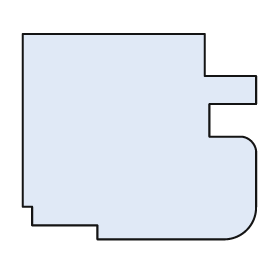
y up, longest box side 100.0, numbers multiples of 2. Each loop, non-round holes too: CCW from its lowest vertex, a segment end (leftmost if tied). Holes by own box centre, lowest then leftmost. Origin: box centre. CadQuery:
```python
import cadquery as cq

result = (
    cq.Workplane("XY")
    .moveTo(-18.0, -44.0)
    .lineTo(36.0, -44.0)
    .threePointArc((46.0, -40.0), (50.0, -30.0))
    .lineTo(50.0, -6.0)
    .threePointArc((48.0, -2.0), (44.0, 0.0))
    .lineTo(30.0, 0.0)
    .lineTo(30.0, 14.0)
    .lineTo(50.0, 14.0)
    .lineTo(50.0, 26.0)
    .lineTo(28.0, 26.0)
    .lineTo(28.0, 44.0)
    .lineTo(-50.0, 44.0)
    .lineTo(-50.0, -30.0)
    .lineTo(-46.0, -30.0)
    .lineTo(-46.0, -38.0)
    .lineTo(-18.0, -38.0)
    .close()
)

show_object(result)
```